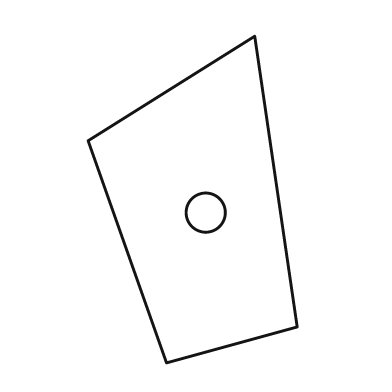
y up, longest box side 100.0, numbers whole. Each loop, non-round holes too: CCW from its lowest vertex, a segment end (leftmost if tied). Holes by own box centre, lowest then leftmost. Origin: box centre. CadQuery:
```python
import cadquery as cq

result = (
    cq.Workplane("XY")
    .moveTo(-8.0, -50.0)
    .lineTo(32.0, -39.0)
    .lineTo(19.0, 50.0)
    .lineTo(-32.0, 18.0)
    .close()
    .moveTo(4.0, -4.0)
    .circle(6.0)
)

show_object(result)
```